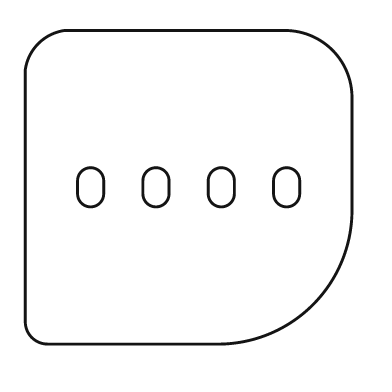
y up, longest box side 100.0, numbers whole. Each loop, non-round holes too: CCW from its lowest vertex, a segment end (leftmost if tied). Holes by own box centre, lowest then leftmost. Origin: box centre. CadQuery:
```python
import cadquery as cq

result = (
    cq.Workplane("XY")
    .moveTo(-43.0, -48.0)
    .lineTo(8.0, -48.0)
    .threePointArc((38.0, -36.0), (50.0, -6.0))
    .lineTo(50.0, 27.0)
    .threePointArc((44.0, 42.0), (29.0, 48.0))
    .lineTo(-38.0, 48.0)
    .threePointArc((-46.0, 44.0), (-50.0, 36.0))
    .lineTo(-50.0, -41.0)
    .threePointArc((-48.0, -46.0), (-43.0, -48.0))
    .close()
    .moveTo(-34.0, -2.0)
    .threePointArc((-30.0, -6.0), (-26.0, -2.0))
    .lineTo(-26.0, 2.0)
    .threePointArc((-30.0, 6.0), (-34.0, 2.0))
    .close()
    .moveTo(-14.0, -2.0)
    .threePointArc((-10.0, -6.0), (-6.0, -2.0))
    .lineTo(-6.0, 2.0)
    .threePointArc((-10.0, 6.0), (-14.0, 2.0))
    .close()
    .moveTo(6.0, -2.0)
    .threePointArc((10.0, -6.0), (14.0, -2.0))
    .lineTo(14.0, 2.0)
    .threePointArc((10.0, 6.0), (6.0, 2.0))
    .close()
    .moveTo(26.0, -2.0)
    .threePointArc((30.0, -6.0), (34.0, -2.0))
    .lineTo(34.0, 2.0)
    .threePointArc((30.0, 6.0), (26.0, 2.0))
    .close()
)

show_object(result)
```